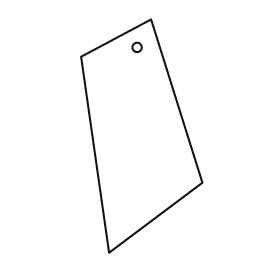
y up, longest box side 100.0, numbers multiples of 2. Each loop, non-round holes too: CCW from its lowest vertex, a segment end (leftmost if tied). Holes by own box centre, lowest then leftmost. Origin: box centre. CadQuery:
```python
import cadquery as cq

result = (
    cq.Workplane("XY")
    .moveTo(-14.0, -50.0)
    .lineTo(26.0, -20.0)
    .lineTo(4.0, 50.0)
    .lineTo(-26.0, 34.0)
    .close()
    .moveTo(-2.0, 38.0)
    .circle(2.0)
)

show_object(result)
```